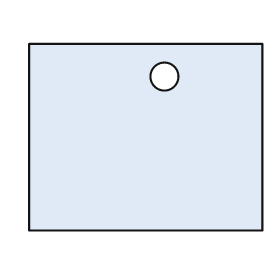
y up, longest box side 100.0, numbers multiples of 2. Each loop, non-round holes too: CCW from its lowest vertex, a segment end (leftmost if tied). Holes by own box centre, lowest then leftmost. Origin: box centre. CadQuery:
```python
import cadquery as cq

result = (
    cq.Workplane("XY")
    .moveTo(-50.0, -40.0)
    .lineTo(50.0, -40.0)
    .lineTo(50.0, 40.0)
    .lineTo(-50.0, 40.0)
    .close()
    .moveTo(8.0, 26.0)
    .circle(6.0)
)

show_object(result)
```